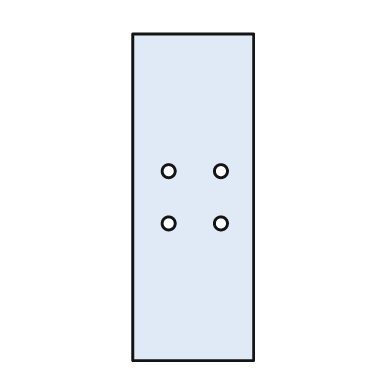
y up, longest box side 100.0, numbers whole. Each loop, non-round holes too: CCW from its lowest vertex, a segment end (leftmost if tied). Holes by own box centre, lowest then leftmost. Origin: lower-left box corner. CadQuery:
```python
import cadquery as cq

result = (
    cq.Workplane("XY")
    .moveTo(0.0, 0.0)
    .lineTo(37.0, 0.0)
    .lineTo(37.0, 100.0)
    .lineTo(0.0, 100.0)
    .close()
    .moveTo(11.0, 42.0)
    .circle(2.0)
    .moveTo(27.0, 42.0)
    .circle(2.0)
    .moveTo(11.0, 58.0)
    .circle(2.0)
    .moveTo(27.0, 58.0)
    .circle(2.0)
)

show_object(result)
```